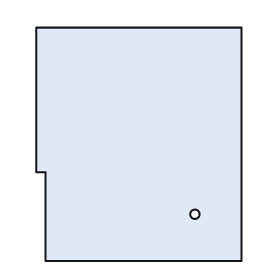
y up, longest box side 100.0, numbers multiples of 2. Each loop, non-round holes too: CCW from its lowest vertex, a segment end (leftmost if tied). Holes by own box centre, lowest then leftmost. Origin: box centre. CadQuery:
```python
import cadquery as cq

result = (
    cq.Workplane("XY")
    .moveTo(-40.0, -50.0)
    .lineTo(44.0, -50.0)
    .lineTo(44.0, 50.0)
    .lineTo(-44.0, 50.0)
    .lineTo(-44.0, -12.0)
    .lineTo(-40.0, -12.0)
    .close()
    .moveTo(24.0, -30.0)
    .circle(2.0)
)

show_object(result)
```